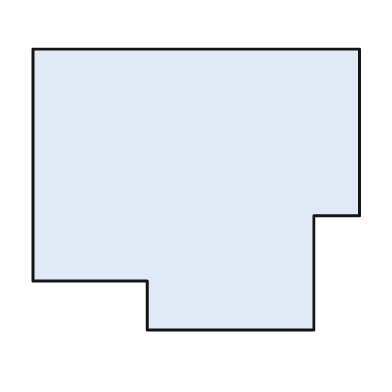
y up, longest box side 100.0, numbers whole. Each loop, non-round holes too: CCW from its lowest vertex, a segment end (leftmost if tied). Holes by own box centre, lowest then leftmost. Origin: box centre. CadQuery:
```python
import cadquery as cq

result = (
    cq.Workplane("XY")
    .moveTo(-15.0, -43.0)
    .lineTo(36.0, -43.0)
    .lineTo(36.0, -8.0)
    .lineTo(50.0, -8.0)
    .lineTo(50.0, 43.0)
    .lineTo(-50.0, 43.0)
    .lineTo(-50.0, -28.0)
    .lineTo(-15.0, -28.0)
    .close()
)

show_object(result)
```